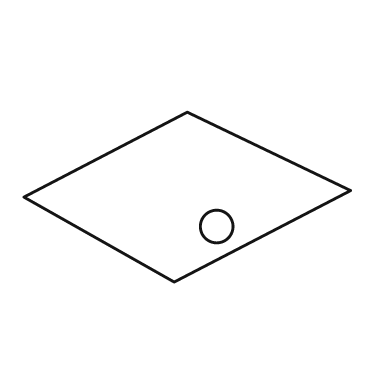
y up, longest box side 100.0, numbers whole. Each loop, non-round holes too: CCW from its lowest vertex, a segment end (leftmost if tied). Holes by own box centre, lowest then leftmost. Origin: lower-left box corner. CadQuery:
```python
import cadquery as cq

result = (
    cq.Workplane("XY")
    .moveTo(46.0, 0.0)
    .lineTo(100.0, 28.0)
    .lineTo(50.0, 52.0)
    .lineTo(0.0, 26.0)
    .close()
    .moveTo(59.0, 17.0)
    .circle(5.0)
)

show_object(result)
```